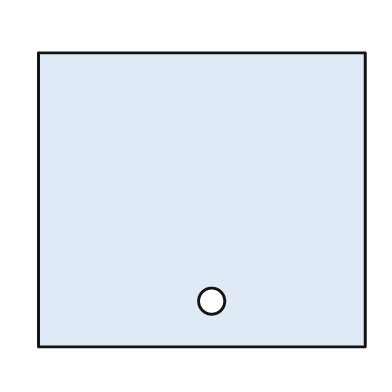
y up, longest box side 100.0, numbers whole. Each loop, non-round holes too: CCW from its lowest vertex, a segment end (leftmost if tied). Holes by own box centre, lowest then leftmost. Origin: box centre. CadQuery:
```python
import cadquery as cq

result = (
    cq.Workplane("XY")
    .moveTo(-50.0, -45.0)
    .lineTo(50.0, -45.0)
    .lineTo(50.0, 45.0)
    .lineTo(-50.0, 45.0)
    .close()
    .moveTo(3.0, -31.0)
    .circle(4.0)
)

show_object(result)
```